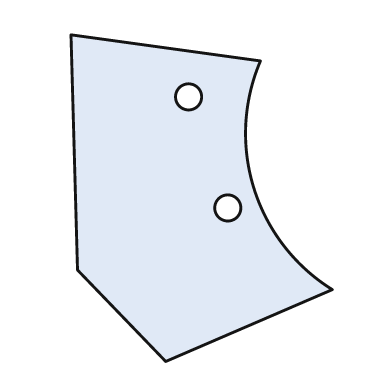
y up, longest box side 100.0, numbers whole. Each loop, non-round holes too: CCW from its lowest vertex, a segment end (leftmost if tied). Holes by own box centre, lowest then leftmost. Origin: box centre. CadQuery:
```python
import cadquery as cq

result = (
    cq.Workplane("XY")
    .moveTo(-11.0, -50.0)
    .lineTo(40.0, -28.0)
    .threePointArc((16.0, 3.0), (18.0, 42.0))
    .lineTo(-40.0, 50.0)
    .lineTo(-38.0, -22.0)
    .close()
    .moveTo(8.0, -3.0)
    .circle(4.0)
    .moveTo(-4.0, 31.0)
    .circle(4.0)
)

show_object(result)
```